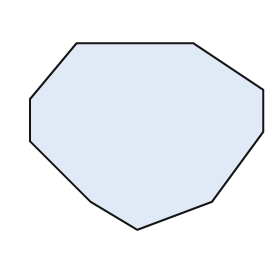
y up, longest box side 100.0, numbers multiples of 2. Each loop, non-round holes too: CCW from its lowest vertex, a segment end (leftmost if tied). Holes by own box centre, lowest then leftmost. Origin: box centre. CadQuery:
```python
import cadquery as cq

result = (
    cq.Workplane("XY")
    .moveTo(-4.0, -40.0)
    .lineTo(28.0, -28.0)
    .lineTo(50.0, 2.0)
    .lineTo(50.0, 20.0)
    .lineTo(20.0, 40.0)
    .lineTo(-30.0, 40.0)
    .lineTo(-50.0, 16.0)
    .lineTo(-50.0, -2.0)
    .lineTo(-24.0, -28.0)
    .close()
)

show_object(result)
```